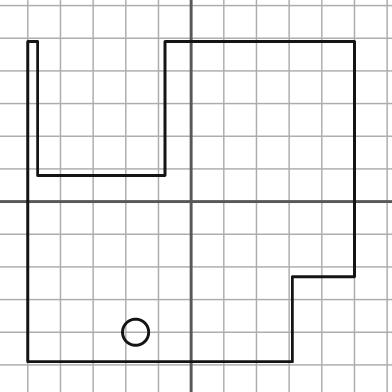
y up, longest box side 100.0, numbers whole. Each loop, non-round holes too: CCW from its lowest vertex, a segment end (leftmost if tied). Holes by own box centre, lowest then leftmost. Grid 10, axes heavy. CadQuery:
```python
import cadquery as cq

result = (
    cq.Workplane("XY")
    .moveTo(-50.0, -49.0)
    .lineTo(31.0, -49.0)
    .lineTo(31.0, -23.0)
    .lineTo(50.0, -23.0)
    .lineTo(50.0, 49.0)
    .lineTo(-8.0, 49.0)
    .lineTo(-8.0, 8.0)
    .lineTo(-47.0, 8.0)
    .lineTo(-47.0, 49.0)
    .lineTo(-50.0, 49.0)
    .close()
    .moveTo(-17.0, -40.0)
    .circle(4.0)
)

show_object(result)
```